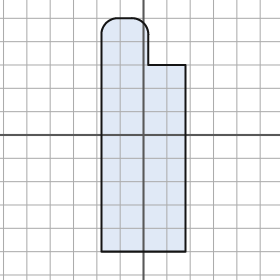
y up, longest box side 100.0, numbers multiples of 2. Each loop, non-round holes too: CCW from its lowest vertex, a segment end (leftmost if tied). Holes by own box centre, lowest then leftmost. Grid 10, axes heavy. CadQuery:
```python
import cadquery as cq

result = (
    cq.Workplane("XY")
    .moveTo(-18.0, -50.0)
    .lineTo(18.0, -50.0)
    .lineTo(18.0, 30.0)
    .lineTo(2.0, 30.0)
    .lineTo(2.0, 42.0)
    .threePointArc((0.0, 48.0), (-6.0, 50.0))
    .lineTo(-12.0, 50.0)
    .threePointArc((-16.0, 48.0), (-18.0, 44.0))
    .close()
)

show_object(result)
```